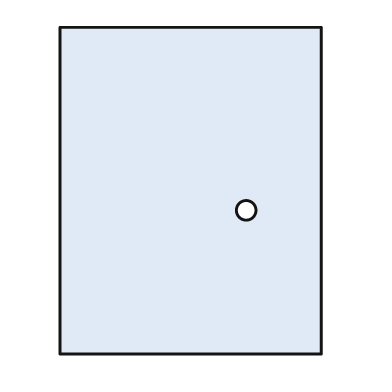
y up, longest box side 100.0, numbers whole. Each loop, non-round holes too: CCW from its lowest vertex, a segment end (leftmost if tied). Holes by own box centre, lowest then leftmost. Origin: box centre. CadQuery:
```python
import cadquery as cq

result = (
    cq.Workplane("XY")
    .moveTo(-40.0, -50.0)
    .lineTo(40.0, -50.0)
    .lineTo(40.0, 50.0)
    .lineTo(-40.0, 50.0)
    .close()
    .moveTo(17.0, -6.0)
    .circle(3.0)
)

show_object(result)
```